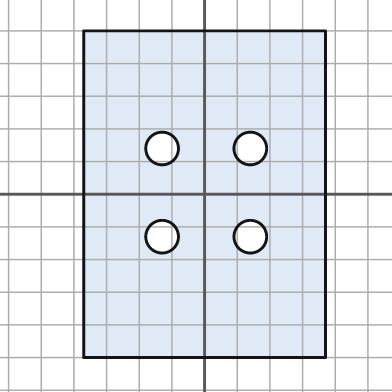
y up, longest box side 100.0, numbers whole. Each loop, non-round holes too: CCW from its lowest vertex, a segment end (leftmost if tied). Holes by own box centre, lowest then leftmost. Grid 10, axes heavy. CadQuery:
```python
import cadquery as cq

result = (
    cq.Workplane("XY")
    .moveTo(-37.0, -50.0)
    .lineTo(37.0, -50.0)
    .lineTo(37.0, 50.0)
    .lineTo(-37.0, 50.0)
    .close()
    .moveTo(-13.0, -13.0)
    .circle(5.0)
    .moveTo(14.0, -13.0)
    .circle(5.0)
    .moveTo(-13.0, 14.0)
    .circle(5.0)
    .moveTo(14.0, 14.0)
    .circle(5.0)
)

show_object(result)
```